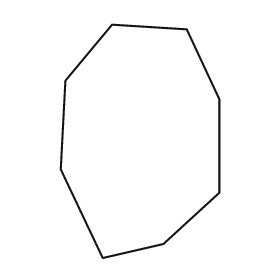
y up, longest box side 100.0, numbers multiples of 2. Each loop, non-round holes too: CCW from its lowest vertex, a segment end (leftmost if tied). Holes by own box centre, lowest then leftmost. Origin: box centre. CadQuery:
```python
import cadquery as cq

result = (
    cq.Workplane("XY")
    .moveTo(-16.0, -50.0)
    .lineTo(10.0, -44.0)
    .lineTo(34.0, -22.0)
    .lineTo(34.0, 18.0)
    .lineTo(20.0, 48.0)
    .lineTo(-12.0, 50.0)
    .lineTo(-32.0, 26.0)
    .lineTo(-34.0, -12.0)
    .close()
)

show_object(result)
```